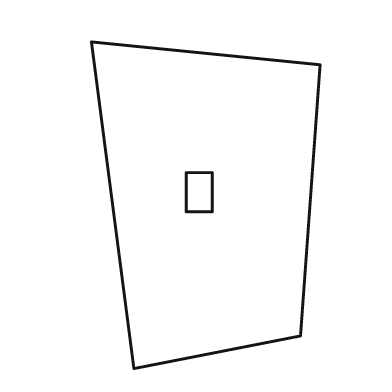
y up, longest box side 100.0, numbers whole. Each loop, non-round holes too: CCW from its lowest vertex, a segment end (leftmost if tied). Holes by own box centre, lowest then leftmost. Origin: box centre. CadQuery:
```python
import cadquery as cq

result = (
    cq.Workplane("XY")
    .moveTo(-22.0, -50.0)
    .lineTo(29.0, -40.0)
    .lineTo(35.0, 43.0)
    .lineTo(-35.0, 50.0)
    .close()
    .moveTo(-6.0, -2.0)
    .lineTo(2.0, -2.0)
    .lineTo(2.0, 10.0)
    .lineTo(-6.0, 10.0)
    .close()
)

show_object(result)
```